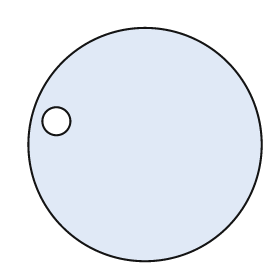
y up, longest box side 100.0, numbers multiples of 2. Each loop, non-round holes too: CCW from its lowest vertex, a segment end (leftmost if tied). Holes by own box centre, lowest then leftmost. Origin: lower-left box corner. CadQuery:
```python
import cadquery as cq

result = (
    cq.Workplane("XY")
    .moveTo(50.0, 50.0)
    .circle(50.0)
    .moveTo(12.0, 60.0)
    .circle(6.0)
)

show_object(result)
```